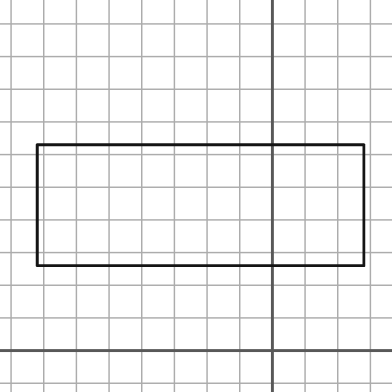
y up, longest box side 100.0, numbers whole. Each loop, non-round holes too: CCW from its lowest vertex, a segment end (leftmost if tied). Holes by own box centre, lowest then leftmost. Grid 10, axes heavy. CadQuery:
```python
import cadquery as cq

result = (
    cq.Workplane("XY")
    .moveTo(-72.0, 26.0)
    .lineTo(28.0, 26.0)
    .lineTo(28.0, 63.0)
    .lineTo(-72.0, 63.0)
    .close()
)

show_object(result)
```